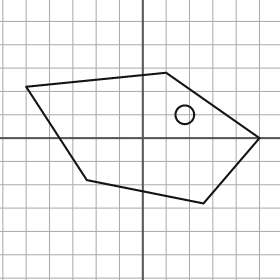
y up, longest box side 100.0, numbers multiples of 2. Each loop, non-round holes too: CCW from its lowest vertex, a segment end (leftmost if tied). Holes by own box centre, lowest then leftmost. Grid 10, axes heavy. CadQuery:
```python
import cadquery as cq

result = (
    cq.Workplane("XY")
    .moveTo(26.0, -28.0)
    .lineTo(50.0, 0.0)
    .lineTo(10.0, 28.0)
    .lineTo(-50.0, 22.0)
    .lineTo(-24.0, -18.0)
    .close()
    .moveTo(18.0, 10.0)
    .circle(4.0)
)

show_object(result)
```